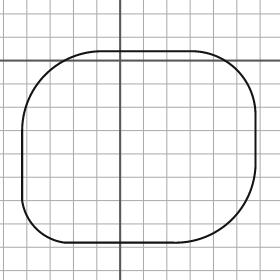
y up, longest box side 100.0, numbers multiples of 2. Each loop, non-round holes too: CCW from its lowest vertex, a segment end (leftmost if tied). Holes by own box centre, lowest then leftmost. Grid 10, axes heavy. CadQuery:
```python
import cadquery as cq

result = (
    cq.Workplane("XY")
    .moveTo(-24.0, -78.0)
    .lineTo(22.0, -78.0)
    .threePointArc((48.0, -68.0), (58.0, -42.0))
    .lineTo(58.0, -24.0)
    .threePointArc((50.0, -4.0), (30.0, 4.0))
    .lineTo(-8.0, 4.0)
    .threePointArc((-32.0, -6.0), (-42.0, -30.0))
    .lineTo(-42.0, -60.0)
    .threePointArc((-36.0, -72.0), (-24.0, -78.0))
    .close()
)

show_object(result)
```